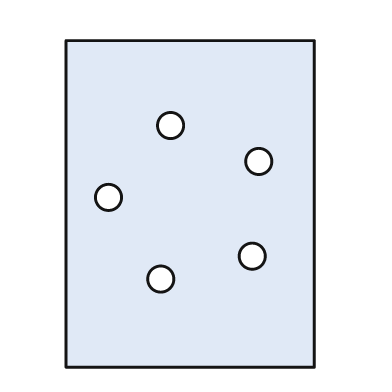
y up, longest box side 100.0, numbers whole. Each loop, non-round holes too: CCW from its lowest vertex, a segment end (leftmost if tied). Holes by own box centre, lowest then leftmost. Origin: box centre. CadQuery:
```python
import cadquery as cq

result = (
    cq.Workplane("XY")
    .moveTo(-38.0, -50.0)
    .lineTo(38.0, -50.0)
    .lineTo(38.0, 50.0)
    .lineTo(-38.0, 50.0)
    .close()
    .moveTo(-9.0, -23.0)
    .circle(4.0)
    .moveTo(19.0, -16.0)
    .circle(4.0)
    .moveTo(-25.0, 2.0)
    .circle(4.0)
    .moveTo(21.0, 13.0)
    .circle(4.0)
    .moveTo(-6.0, 24.0)
    .circle(4.0)
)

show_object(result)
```